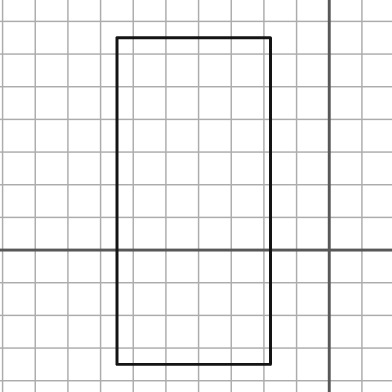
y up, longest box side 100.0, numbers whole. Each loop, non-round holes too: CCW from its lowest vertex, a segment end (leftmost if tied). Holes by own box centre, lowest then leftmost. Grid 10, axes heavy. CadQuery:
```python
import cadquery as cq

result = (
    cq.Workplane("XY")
    .moveTo(-65.0, -35.0)
    .lineTo(-18.0, -35.0)
    .lineTo(-18.0, 65.0)
    .lineTo(-65.0, 65.0)
    .close()
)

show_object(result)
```